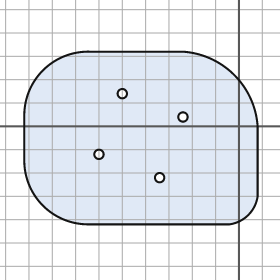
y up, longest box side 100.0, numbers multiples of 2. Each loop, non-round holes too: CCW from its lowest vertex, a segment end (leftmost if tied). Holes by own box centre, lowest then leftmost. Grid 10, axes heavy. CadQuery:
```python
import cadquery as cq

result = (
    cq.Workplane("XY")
    .moveTo(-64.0, -42.0)
    .lineTo(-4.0, -42.0)
    .threePointArc((4.0, -38.0), (8.0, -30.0))
    .lineTo(8.0, 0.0)
    .threePointArc((-2.0, 22.0), (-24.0, 32.0))
    .lineTo(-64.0, 32.0)
    .threePointArc((-84.0, 24.0), (-92.0, 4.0))
    .lineTo(-92.0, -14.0)
    .threePointArc((-84.0, -34.0), (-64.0, -42.0))
    .close()
    .moveTo(-34.0, -22.0)
    .circle(2.0)
    .moveTo(-60.0, -12.0)
    .circle(2.0)
    .moveTo(-24.0, 4.0)
    .circle(2.0)
    .moveTo(-50.0, 14.0)
    .circle(2.0)
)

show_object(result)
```